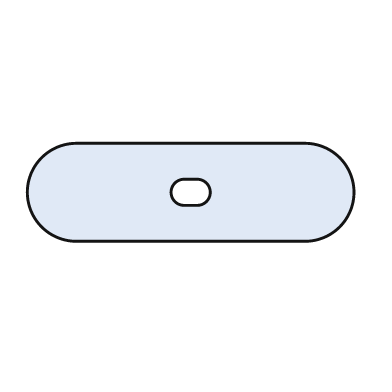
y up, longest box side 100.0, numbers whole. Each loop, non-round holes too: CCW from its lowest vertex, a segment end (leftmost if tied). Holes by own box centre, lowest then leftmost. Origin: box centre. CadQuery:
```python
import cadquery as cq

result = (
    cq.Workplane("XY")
    .moveTo(-35.0, -15.0)
    .lineTo(35.0, -15.0)
    .threePointArc((50.0, 0.0), (35.0, 15.0))
    .lineTo(-35.0, 15.0)
    .threePointArc((-50.0, 0.0), (-35.0, -15.0))
    .close()
    .moveTo(-2.0, -4.0)
    .lineTo(2.0, -4.0)
    .threePointArc((6.0, 0.0), (2.0, 4.0))
    .lineTo(-2.0, 4.0)
    .threePointArc((-6.0, 0.0), (-2.0, -4.0))
    .close()
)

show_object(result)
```